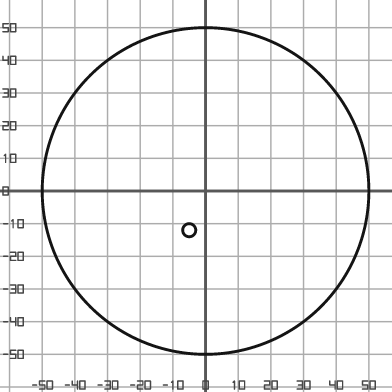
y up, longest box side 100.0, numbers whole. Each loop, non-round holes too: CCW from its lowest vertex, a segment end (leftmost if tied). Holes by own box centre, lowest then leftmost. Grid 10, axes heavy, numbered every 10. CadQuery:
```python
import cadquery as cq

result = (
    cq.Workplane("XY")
    .moveTo(0.0, 0.0)
    .circle(50.0)
    .moveTo(-5.0, -12.0)
    .circle(2.0)
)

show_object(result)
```